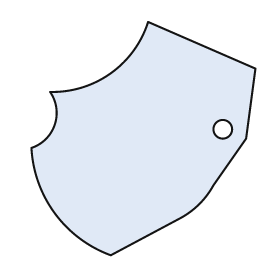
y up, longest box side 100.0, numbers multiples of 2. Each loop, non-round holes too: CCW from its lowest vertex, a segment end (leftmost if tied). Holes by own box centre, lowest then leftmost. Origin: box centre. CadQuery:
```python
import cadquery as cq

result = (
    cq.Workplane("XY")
    .moveTo(-14.0, -50.0)
    .lineTo(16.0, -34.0)
    .threePointArc((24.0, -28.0), (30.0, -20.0))
    .lineTo(44.0, 0.0)
    .lineTo(48.0, 30.0)
    .lineTo(2.0, 50.0)
    .threePointArc((-14.0, 28.0), (-40.0, 20.0))
    .threePointArc((-38.0, 6.0), (-48.0, -4.0))
    .threePointArc((-38.0, -32.0), (-14.0, -50.0))
    .close()
    .moveTo(34.0, 4.0)
    .circle(4.0)
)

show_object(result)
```